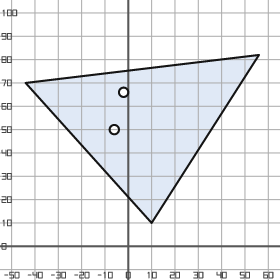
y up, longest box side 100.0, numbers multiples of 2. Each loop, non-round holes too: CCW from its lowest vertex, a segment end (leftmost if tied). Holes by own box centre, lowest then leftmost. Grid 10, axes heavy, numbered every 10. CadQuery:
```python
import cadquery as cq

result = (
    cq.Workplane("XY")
    .moveTo(10.0, 10.0)
    .lineTo(56.0, 82.0)
    .lineTo(-44.0, 70.0)
    .close()
    .moveTo(-6.0, 50.0)
    .circle(2.0)
    .moveTo(-2.0, 66.0)
    .circle(2.0)
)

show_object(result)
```